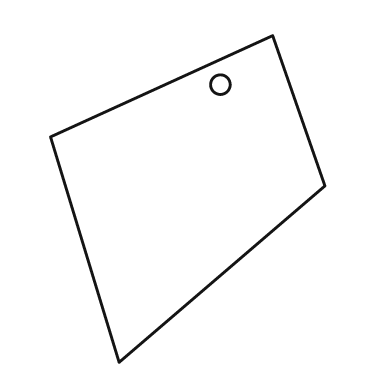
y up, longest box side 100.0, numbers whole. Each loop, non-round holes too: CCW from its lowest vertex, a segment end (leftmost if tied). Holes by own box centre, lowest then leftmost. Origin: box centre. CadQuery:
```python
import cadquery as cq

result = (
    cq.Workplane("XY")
    .moveTo(-21.0, -50.0)
    .lineTo(42.0, 4.0)
    .lineTo(26.0, 50.0)
    .lineTo(-42.0, 19.0)
    .close()
    .moveTo(10.0, 35.0)
    .circle(3.0)
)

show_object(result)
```